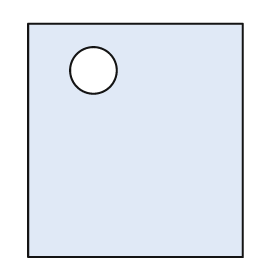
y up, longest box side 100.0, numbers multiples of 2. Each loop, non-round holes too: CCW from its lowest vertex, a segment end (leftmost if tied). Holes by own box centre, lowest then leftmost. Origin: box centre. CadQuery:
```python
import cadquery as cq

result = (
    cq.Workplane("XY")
    .moveTo(-46.0, -50.0)
    .lineTo(46.0, -50.0)
    .lineTo(46.0, 50.0)
    .lineTo(-46.0, 50.0)
    .close()
    .moveTo(-18.0, 30.0)
    .circle(10.0)
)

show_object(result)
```